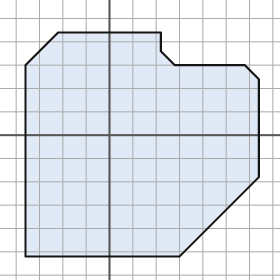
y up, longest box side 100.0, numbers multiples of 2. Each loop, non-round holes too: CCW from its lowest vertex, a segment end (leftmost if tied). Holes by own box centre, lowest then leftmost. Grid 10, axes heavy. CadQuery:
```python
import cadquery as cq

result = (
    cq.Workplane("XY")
    .moveTo(-36.0, -52.0)
    .lineTo(30.0, -52.0)
    .lineTo(64.0, -18.0)
    .lineTo(64.0, 24.0)
    .lineTo(58.0, 30.0)
    .lineTo(28.0, 30.0)
    .lineTo(22.0, 36.0)
    .lineTo(22.0, 44.0)
    .lineTo(-22.0, 44.0)
    .lineTo(-36.0, 30.0)
    .close()
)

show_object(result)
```